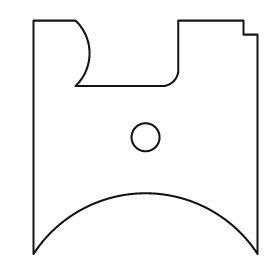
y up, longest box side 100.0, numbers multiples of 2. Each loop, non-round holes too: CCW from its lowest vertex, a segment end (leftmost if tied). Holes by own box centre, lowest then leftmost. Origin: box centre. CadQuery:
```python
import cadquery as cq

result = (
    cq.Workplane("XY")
    .moveTo(-48.0, -50.0)
    .threePointArc((0.0, -24.0), (48.0, -50.0))
    .lineTo(48.0, 44.0)
    .lineTo(42.0, 44.0)
    .lineTo(42.0, 50.0)
    .lineTo(14.0, 50.0)
    .lineTo(14.0, 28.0)
    .threePointArc((12.0, 24.0), (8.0, 22.0))
    .lineTo(-30.0, 22.0)
    .threePointArc((-24.0, 36.0), (-30.0, 50.0))
    .lineTo(-48.0, 50.0)
    .close()
    .moveTo(0.0, 0.0)
    .circle(6.0)
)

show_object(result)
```